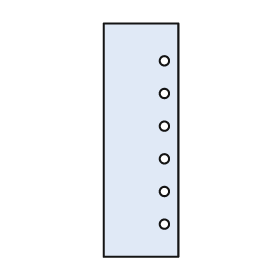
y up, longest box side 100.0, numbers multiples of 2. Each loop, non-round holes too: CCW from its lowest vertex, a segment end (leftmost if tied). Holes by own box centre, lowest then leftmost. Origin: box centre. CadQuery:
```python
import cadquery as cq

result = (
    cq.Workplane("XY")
    .moveTo(-16.0, -50.0)
    .lineTo(16.0, -50.0)
    .lineTo(16.0, 50.0)
    .lineTo(-16.0, 50.0)
    .close()
    .moveTo(10.0, -36.0)
    .circle(2.0)
    .moveTo(10.0, -22.0)
    .circle(2.0)
    .moveTo(10.0, -8.0)
    .circle(2.0)
    .moveTo(10.0, 6.0)
    .circle(2.0)
    .moveTo(10.0, 20.0)
    .circle(2.0)
    .moveTo(10.0, 34.0)
    .circle(2.0)
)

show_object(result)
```